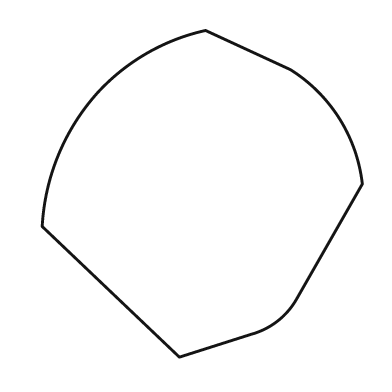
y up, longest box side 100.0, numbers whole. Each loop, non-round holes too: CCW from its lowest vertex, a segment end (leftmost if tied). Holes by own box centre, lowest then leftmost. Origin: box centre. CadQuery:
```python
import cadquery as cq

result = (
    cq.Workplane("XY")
    .moveTo(-7.0, -50.0)
    .lineTo(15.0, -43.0)
    .threePointArc((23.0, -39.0), (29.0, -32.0))
    .lineTo(49.0, 3.0)
    .threePointArc((42.0, 23.0), (27.0, 38.0))
    .lineTo(1.0, 50.0)
    .threePointArc((-17.0, 43.0), (-32.0, 31.0))
    .threePointArc((-44.0, 12.0), (-49.0, -10.0))
    .close()
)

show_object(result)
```